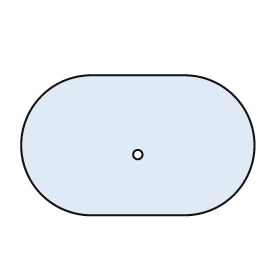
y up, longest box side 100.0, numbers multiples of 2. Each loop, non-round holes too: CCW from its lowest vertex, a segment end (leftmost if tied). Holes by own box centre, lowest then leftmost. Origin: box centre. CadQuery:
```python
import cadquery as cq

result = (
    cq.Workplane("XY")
    .moveTo(-20.0, -30.0)
    .lineTo(20.0, -30.0)
    .threePointArc((50.0, 0.0), (20.0, 30.0))
    .lineTo(-20.0, 30.0)
    .threePointArc((-50.0, 0.0), (-20.0, -30.0))
    .close()
    .moveTo(0.0, -4.0)
    .circle(2.0)
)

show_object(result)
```